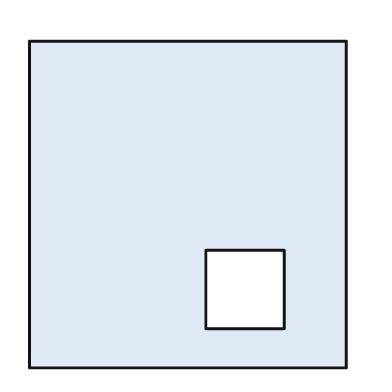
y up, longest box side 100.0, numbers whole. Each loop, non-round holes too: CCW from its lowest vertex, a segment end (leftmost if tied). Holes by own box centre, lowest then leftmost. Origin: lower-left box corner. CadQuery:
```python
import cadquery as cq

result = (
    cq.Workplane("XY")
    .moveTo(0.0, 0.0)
    .lineTo(97.0, 0.0)
    .lineTo(97.0, 100.0)
    .lineTo(0.0, 100.0)
    .close()
    .moveTo(54.0, 12.0)
    .lineTo(78.0, 12.0)
    .lineTo(78.0, 36.0)
    .lineTo(54.0, 36.0)
    .close()
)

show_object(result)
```